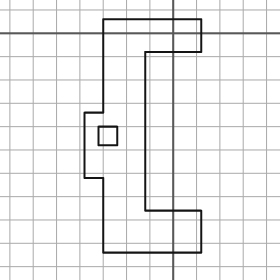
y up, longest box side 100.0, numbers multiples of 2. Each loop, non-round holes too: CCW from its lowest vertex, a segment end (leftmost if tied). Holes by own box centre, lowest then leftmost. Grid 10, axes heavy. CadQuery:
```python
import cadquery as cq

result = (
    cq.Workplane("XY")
    .moveTo(-30.0, -94.0)
    .lineTo(12.0, -94.0)
    .lineTo(12.0, -76.0)
    .lineTo(-12.0, -76.0)
    .lineTo(-12.0, -8.0)
    .lineTo(12.0, -8.0)
    .lineTo(12.0, 6.0)
    .lineTo(-30.0, 6.0)
    .lineTo(-30.0, -34.0)
    .lineTo(-38.0, -34.0)
    .lineTo(-38.0, -62.0)
    .lineTo(-30.0, -62.0)
    .close()
    .moveTo(-32.0, -48.0)
    .lineTo(-24.0, -48.0)
    .lineTo(-24.0, -40.0)
    .lineTo(-32.0, -40.0)
    .close()
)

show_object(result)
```